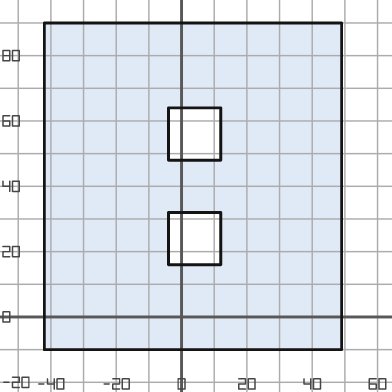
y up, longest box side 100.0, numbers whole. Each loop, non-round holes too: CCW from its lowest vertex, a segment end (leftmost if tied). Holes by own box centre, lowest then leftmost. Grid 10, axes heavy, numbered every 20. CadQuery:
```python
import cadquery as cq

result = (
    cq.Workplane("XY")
    .moveTo(-42.0, -10.0)
    .lineTo(49.0, -10.0)
    .lineTo(49.0, 90.0)
    .lineTo(-42.0, 90.0)
    .close()
    .moveTo(-4.0, 16.0)
    .lineTo(12.0, 16.0)
    .lineTo(12.0, 32.0)
    .lineTo(-4.0, 32.0)
    .close()
    .moveTo(-4.0, 48.0)
    .lineTo(12.0, 48.0)
    .lineTo(12.0, 64.0)
    .lineTo(-4.0, 64.0)
    .close()
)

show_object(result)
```